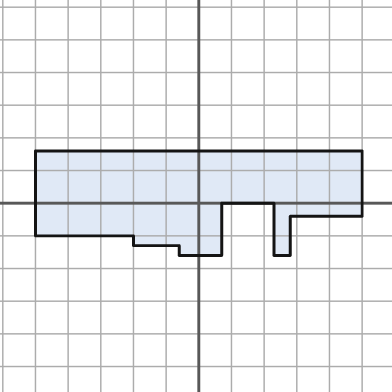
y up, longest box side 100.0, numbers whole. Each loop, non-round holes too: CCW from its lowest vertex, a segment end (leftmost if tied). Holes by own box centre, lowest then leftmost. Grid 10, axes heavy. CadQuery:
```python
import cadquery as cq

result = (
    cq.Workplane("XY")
    .moveTo(-6.0, -16.0)
    .lineTo(7.0, -16.0)
    .lineTo(7.0, 0.0)
    .lineTo(23.0, 0.0)
    .lineTo(23.0, -16.0)
    .lineTo(28.0, -16.0)
    .lineTo(28.0, -4.0)
    .lineTo(50.0, -4.0)
    .lineTo(50.0, 16.0)
    .lineTo(-50.0, 16.0)
    .lineTo(-50.0, -10.0)
    .lineTo(-20.0, -10.0)
    .lineTo(-20.0, -13.0)
    .lineTo(-6.0, -13.0)
    .close()
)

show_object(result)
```